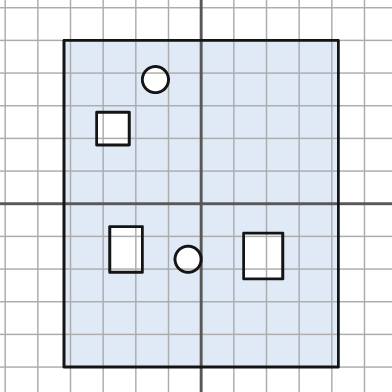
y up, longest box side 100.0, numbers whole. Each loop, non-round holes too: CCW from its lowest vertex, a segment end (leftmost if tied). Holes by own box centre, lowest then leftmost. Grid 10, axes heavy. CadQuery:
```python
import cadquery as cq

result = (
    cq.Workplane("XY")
    .moveTo(-42.0, -50.0)
    .lineTo(42.0, -50.0)
    .lineTo(42.0, 50.0)
    .lineTo(-42.0, 50.0)
    .close()
    .moveTo(-4.0, -17.0)
    .circle(4.0)
    .moveTo(13.0, -23.0)
    .lineTo(25.0, -23.0)
    .lineTo(25.0, -9.0)
    .lineTo(13.0, -9.0)
    .close()
    .moveTo(-28.0, -21.0)
    .lineTo(-18.0, -21.0)
    .lineTo(-18.0, -7.0)
    .lineTo(-28.0, -7.0)
    .close()
    .moveTo(-32.0, 18.0)
    .lineTo(-22.0, 18.0)
    .lineTo(-22.0, 28.0)
    .lineTo(-32.0, 28.0)
    .close()
    .moveTo(-14.0, 38.0)
    .circle(4.0)
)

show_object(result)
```